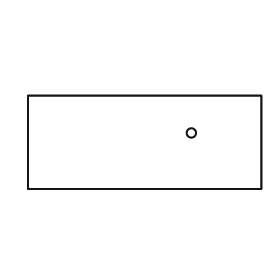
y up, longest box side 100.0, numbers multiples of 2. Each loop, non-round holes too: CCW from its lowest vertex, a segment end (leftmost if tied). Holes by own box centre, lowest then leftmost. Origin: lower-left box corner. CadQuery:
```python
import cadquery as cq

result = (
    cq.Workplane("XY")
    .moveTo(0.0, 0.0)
    .lineTo(100.0, 0.0)
    .lineTo(100.0, 40.0)
    .lineTo(0.0, 40.0)
    .close()
    .moveTo(70.0, 24.0)
    .circle(2.0)
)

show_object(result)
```